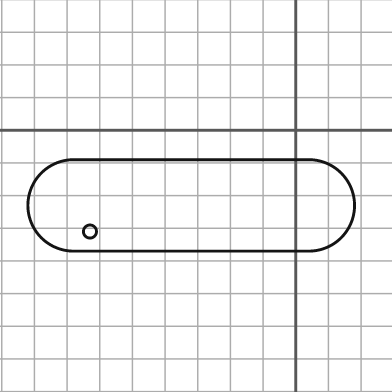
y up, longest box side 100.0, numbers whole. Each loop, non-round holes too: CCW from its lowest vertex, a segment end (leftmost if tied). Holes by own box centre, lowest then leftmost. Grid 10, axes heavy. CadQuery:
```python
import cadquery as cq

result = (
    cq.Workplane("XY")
    .moveTo(-68.0, -37.0)
    .lineTo(4.0, -37.0)
    .threePointArc((18.0, -23.0), (4.0, -9.0))
    .lineTo(-68.0, -9.0)
    .threePointArc((-82.0, -23.0), (-68.0, -37.0))
    .close()
    .moveTo(-63.0, -31.0)
    .circle(2.0)
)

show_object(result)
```